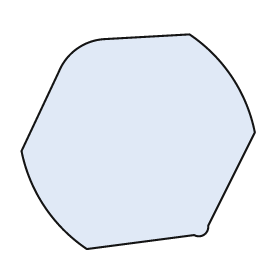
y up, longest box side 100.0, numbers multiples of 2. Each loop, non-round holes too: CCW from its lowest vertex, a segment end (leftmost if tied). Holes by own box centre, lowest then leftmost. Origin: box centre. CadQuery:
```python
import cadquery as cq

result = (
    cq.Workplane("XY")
    .moveTo(-22.0, -46.0)
    .lineTo(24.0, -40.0)
    .threePointArc((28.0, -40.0), (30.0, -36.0))
    .lineTo(50.0, 4.0)
    .threePointArc((40.0, 28.0), (22.0, 46.0))
    .lineTo(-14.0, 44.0)
    .threePointArc((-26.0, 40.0), (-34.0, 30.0))
    .lineTo(-50.0, -4.0)
    .threePointArc((-40.0, -28.0), (-22.0, -46.0))
    .close()
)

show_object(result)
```